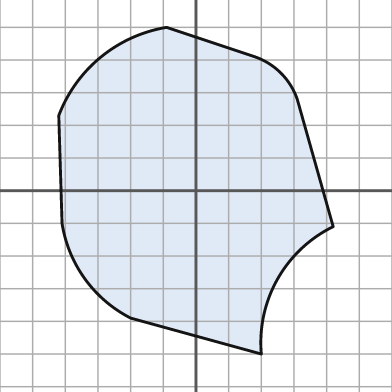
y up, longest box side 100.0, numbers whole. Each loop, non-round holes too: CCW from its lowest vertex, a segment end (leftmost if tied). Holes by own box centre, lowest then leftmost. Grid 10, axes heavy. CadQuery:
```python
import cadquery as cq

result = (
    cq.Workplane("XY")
    .moveTo(20.0, -50.0)
    .threePointArc((25.0, -27.0), (42.0, -11.0))
    .lineTo(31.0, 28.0)
    .threePointArc((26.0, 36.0), (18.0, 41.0))
    .lineTo(-9.0, 50.0)
    .threePointArc((-29.0, 41.0), (-42.0, 23.0))
    .lineTo(-41.0, -10.0)
    .threePointArc((-34.0, -27.0), (-20.0, -39.0))
    .close()
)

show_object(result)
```